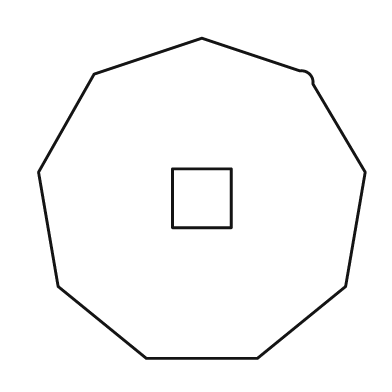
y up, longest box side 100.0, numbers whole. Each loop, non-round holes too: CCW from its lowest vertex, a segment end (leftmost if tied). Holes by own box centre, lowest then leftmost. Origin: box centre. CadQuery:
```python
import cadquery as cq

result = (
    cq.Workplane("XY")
    .moveTo(-17.0, -49.0)
    .lineTo(17.0, -49.0)
    .lineTo(44.0, -27.0)
    .lineTo(50.0, 8.0)
    .lineTo(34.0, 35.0)
    .threePointArc((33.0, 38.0), (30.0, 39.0))
    .lineTo(0.0, 49.0)
    .lineTo(-33.0, 38.0)
    .lineTo(-50.0, 8.0)
    .lineTo(-44.0, -27.0)
    .close()
    .moveTo(-9.0, -9.0)
    .lineTo(9.0, -9.0)
    .lineTo(9.0, 9.0)
    .lineTo(-9.0, 9.0)
    .close()
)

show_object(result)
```